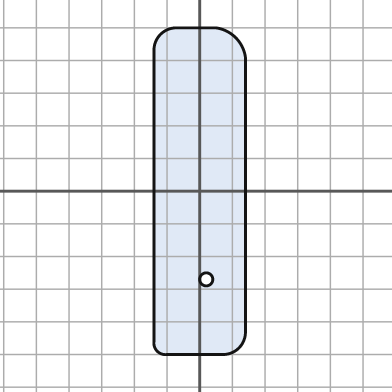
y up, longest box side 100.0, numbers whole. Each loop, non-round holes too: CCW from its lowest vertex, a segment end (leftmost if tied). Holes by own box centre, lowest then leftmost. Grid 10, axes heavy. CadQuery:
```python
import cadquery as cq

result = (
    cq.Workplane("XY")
    .moveTo(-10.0, -50.0)
    .lineTo(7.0, -50.0)
    .threePointArc((12.0, -48.0), (14.0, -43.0))
    .lineTo(14.0, 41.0)
    .threePointArc((11.0, 47.0), (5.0, 50.0))
    .lineTo(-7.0, 50.0)
    .threePointArc((-12.0, 48.0), (-14.0, 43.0))
    .lineTo(-14.0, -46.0)
    .threePointArc((-13.0, -49.0), (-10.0, -50.0))
    .close()
    .moveTo(2.0, -27.0)
    .circle(2.0)
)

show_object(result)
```